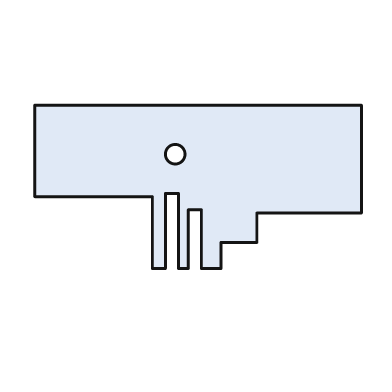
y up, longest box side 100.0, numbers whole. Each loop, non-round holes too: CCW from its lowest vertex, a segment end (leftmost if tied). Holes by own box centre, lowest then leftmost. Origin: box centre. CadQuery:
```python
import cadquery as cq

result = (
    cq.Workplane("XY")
    .moveTo(-14.0, -25.0)
    .lineTo(-10.0, -25.0)
    .lineTo(-10.0, -2.0)
    .lineTo(-6.0, -2.0)
    .lineTo(-6.0, -25.0)
    .lineTo(-3.0, -25.0)
    .lineTo(-3.0, -7.0)
    .lineTo(1.0, -7.0)
    .lineTo(1.0, -25.0)
    .lineTo(7.0, -25.0)
    .lineTo(7.0, -17.0)
    .lineTo(18.0, -17.0)
    .lineTo(18.0, -8.0)
    .lineTo(50.0, -8.0)
    .lineTo(50.0, 25.0)
    .lineTo(-50.0, 25.0)
    .lineTo(-50.0, -3.0)
    .lineTo(-14.0, -3.0)
    .close()
    .moveTo(-7.0, 10.0)
    .circle(3.0)
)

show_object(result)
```